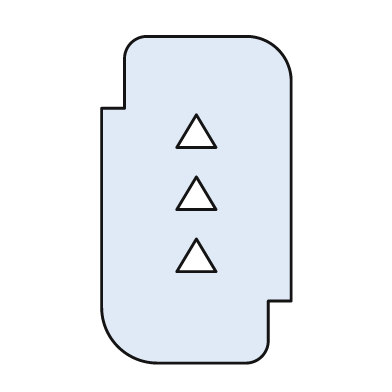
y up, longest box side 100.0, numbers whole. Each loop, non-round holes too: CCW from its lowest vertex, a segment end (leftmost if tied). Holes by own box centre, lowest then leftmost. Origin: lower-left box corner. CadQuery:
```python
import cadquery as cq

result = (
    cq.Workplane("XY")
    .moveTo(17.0, 0.0)
    .lineTo(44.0, 0.0)
    .threePointArc((49.0, 2.0), (51.0, 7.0))
    .lineTo(51.0, 19.0)
    .lineTo(58.0, 19.0)
    .lineTo(58.0, 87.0)
    .threePointArc((54.0, 96.0), (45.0, 100.0))
    .lineTo(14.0, 100.0)
    .threePointArc((9.0, 98.0), (7.0, 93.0))
    .lineTo(7.0, 78.0)
    .lineTo(0.0, 78.0)
    .lineTo(0.0, 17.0)
    .threePointArc((5.0, 5.0), (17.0, 0.0))
    .close()
    .moveTo(23.0, 28.0)
    .lineTo(35.0, 28.0)
    .lineTo(29.0, 38.0)
    .close()
    .moveTo(23.0, 47.0)
    .lineTo(35.0, 47.0)
    .lineTo(29.0, 57.0)
    .close()
    .moveTo(23.0, 66.0)
    .lineTo(35.0, 66.0)
    .lineTo(29.0, 76.0)
    .close()
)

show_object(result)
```